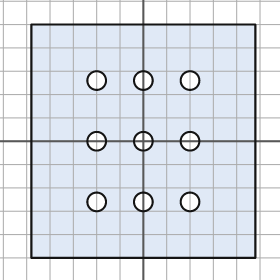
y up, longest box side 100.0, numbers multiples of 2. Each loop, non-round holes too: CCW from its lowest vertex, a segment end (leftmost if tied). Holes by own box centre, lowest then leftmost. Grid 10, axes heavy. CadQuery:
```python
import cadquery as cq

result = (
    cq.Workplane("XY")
    .moveTo(-48.0, -50.0)
    .lineTo(48.0, -50.0)
    .lineTo(48.0, 50.0)
    .lineTo(-48.0, 50.0)
    .close()
    .moveTo(-20.0, -26.0)
    .circle(4.0)
    .moveTo(0.0, -26.0)
    .circle(4.0)
    .moveTo(20.0, -26.0)
    .circle(4.0)
    .moveTo(-20.0, 0.0)
    .circle(4.0)
    .moveTo(0.0, 0.0)
    .circle(4.0)
    .moveTo(20.0, 0.0)
    .circle(4.0)
    .moveTo(-20.0, 26.0)
    .circle(4.0)
    .moveTo(0.0, 26.0)
    .circle(4.0)
    .moveTo(20.0, 26.0)
    .circle(4.0)
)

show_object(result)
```